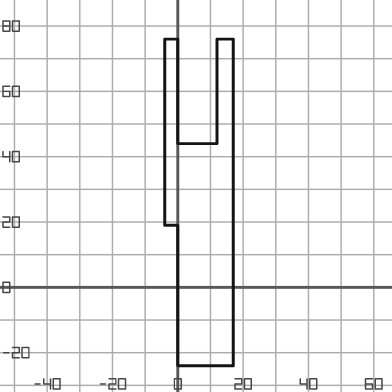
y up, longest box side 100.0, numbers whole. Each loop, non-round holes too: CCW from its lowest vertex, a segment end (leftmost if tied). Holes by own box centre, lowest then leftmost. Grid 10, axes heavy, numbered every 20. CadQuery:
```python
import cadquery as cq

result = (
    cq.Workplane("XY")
    .moveTo(0.0, -24.0)
    .lineTo(17.0, -24.0)
    .lineTo(17.0, 76.0)
    .lineTo(12.0, 76.0)
    .lineTo(12.0, 44.0)
    .lineTo(0.0, 44.0)
    .lineTo(0.0, 76.0)
    .lineTo(-4.0, 76.0)
    .lineTo(-4.0, 19.0)
    .lineTo(0.0, 19.0)
    .close()
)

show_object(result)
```